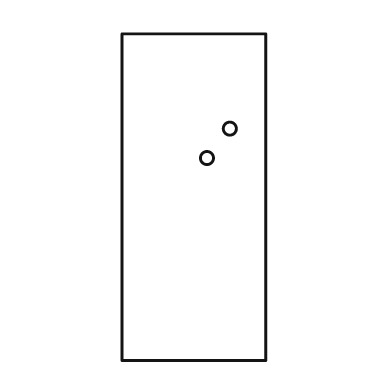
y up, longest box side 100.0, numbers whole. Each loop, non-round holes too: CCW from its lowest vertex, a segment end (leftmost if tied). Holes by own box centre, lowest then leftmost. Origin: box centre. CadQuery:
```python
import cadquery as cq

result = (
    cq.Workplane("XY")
    .moveTo(-22.0, -50.0)
    .lineTo(22.0, -50.0)
    .lineTo(22.0, 50.0)
    .lineTo(-22.0, 50.0)
    .close()
    .moveTo(4.0, 12.0)
    .circle(2.0)
    .moveTo(11.0, 21.0)
    .circle(2.0)
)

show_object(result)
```